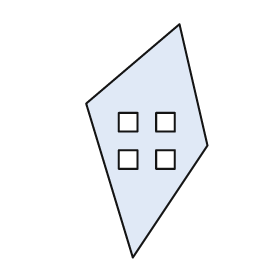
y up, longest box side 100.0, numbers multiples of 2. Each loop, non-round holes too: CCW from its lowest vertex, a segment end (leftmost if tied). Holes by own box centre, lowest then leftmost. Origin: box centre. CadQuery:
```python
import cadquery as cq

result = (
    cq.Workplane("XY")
    .moveTo(-6.0, -50.0)
    .lineTo(26.0, -2.0)
    .lineTo(14.0, 50.0)
    .lineTo(-26.0, 16.0)
    .close()
    .moveTo(-12.0, -12.0)
    .lineTo(-4.0, -12.0)
    .lineTo(-4.0, -4.0)
    .lineTo(-12.0, -4.0)
    .close()
    .moveTo(4.0, -12.0)
    .lineTo(12.0, -12.0)
    .lineTo(12.0, -4.0)
    .lineTo(4.0, -4.0)
    .close()
    .moveTo(-12.0, 4.0)
    .lineTo(-4.0, 4.0)
    .lineTo(-4.0, 12.0)
    .lineTo(-12.0, 12.0)
    .close()
    .moveTo(4.0, 4.0)
    .lineTo(12.0, 4.0)
    .lineTo(12.0, 12.0)
    .lineTo(4.0, 12.0)
    .close()
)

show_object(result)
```